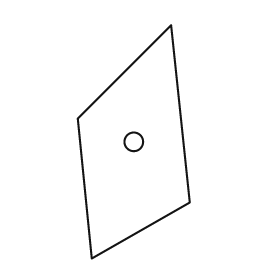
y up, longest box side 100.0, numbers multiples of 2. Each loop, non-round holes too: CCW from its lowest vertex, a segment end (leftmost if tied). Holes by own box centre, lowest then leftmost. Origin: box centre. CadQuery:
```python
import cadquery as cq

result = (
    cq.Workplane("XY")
    .moveTo(-18.0, -50.0)
    .lineTo(24.0, -26.0)
    .lineTo(16.0, 50.0)
    .lineTo(-24.0, 10.0)
    .close()
    .moveTo(0.0, 0.0)
    .circle(4.0)
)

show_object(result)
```